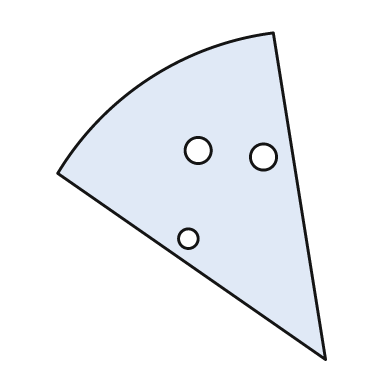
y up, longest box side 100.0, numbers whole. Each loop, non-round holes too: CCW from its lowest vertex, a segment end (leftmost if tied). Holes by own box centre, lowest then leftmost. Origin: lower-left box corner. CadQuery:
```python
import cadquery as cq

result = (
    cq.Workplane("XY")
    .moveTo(82.0, 0.0)
    .lineTo(66.0, 100.0)
    .threePointArc((28.0, 86.0), (0.0, 57.0))
    .close()
    .moveTo(40.0, 37.0)
    .circle(3.0)
    .moveTo(63.0, 62.0)
    .circle(4.0)
    .moveTo(43.0, 64.0)
    .circle(4.0)
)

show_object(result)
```